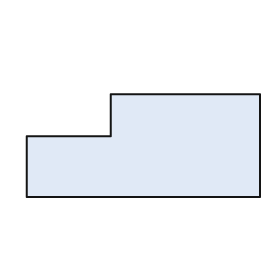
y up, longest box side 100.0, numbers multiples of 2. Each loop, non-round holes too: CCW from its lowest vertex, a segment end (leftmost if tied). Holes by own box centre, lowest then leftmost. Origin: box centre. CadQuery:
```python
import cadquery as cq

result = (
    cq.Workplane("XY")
    .moveTo(-50.0, -22.0)
    .lineTo(50.0, -22.0)
    .lineTo(50.0, 22.0)
    .lineTo(-14.0, 22.0)
    .lineTo(-14.0, 4.0)
    .lineTo(-50.0, 4.0)
    .close()
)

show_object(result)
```